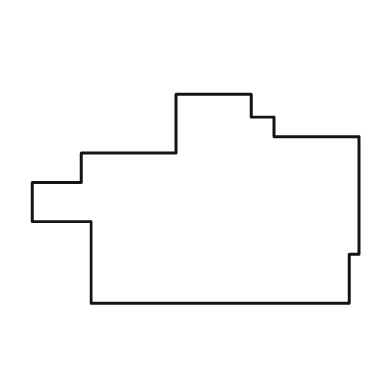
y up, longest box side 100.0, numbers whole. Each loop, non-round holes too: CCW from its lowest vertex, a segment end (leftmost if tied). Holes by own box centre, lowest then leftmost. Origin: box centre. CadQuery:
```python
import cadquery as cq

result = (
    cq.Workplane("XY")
    .moveTo(-32.0, -32.0)
    .lineTo(47.0, -32.0)
    .lineTo(47.0, -17.0)
    .lineTo(50.0, -17.0)
    .lineTo(50.0, 19.0)
    .lineTo(24.0, 19.0)
    .lineTo(24.0, 25.0)
    .lineTo(17.0, 25.0)
    .lineTo(17.0, 32.0)
    .lineTo(-6.0, 32.0)
    .lineTo(-6.0, 14.0)
    .lineTo(-35.0, 14.0)
    .lineTo(-35.0, 5.0)
    .lineTo(-50.0, 5.0)
    .lineTo(-50.0, -7.0)
    .lineTo(-32.0, -7.0)
    .close()
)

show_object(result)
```